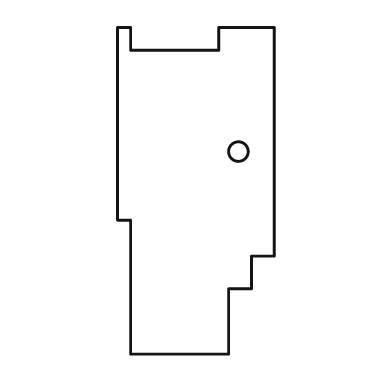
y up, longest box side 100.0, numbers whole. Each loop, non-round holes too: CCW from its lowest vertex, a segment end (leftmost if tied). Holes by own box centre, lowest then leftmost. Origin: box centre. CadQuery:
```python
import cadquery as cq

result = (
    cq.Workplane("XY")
    .moveTo(-20.0, -50.0)
    .lineTo(10.0, -50.0)
    .lineTo(10.0, -30.0)
    .lineTo(17.0, -30.0)
    .lineTo(17.0, -20.0)
    .lineTo(24.0, -20.0)
    .lineTo(24.0, 50.0)
    .lineTo(7.0, 50.0)
    .lineTo(7.0, 43.0)
    .lineTo(-20.0, 43.0)
    .lineTo(-20.0, 50.0)
    .lineTo(-24.0, 50.0)
    .lineTo(-24.0, -9.0)
    .lineTo(-20.0, -9.0)
    .close()
    .moveTo(13.0, 12.0)
    .circle(3.0)
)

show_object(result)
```